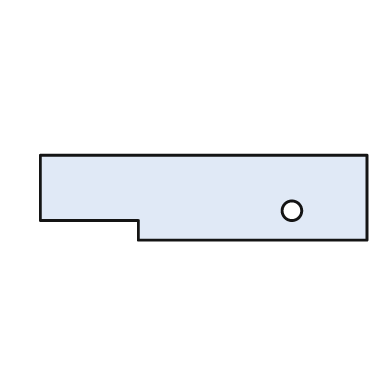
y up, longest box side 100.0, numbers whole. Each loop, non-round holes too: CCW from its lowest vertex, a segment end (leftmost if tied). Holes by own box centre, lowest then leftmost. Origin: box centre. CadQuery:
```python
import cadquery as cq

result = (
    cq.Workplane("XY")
    .moveTo(-20.0, -13.0)
    .lineTo(50.0, -13.0)
    .lineTo(50.0, 13.0)
    .lineTo(-50.0, 13.0)
    .lineTo(-50.0, -7.0)
    .lineTo(-20.0, -7.0)
    .close()
    .moveTo(27.0, -4.0)
    .circle(3.0)
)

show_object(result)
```